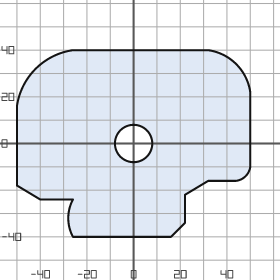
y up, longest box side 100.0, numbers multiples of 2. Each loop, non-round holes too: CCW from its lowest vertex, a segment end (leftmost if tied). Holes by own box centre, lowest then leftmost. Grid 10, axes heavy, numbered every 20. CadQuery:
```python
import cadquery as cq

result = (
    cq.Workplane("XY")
    .moveTo(-26.0, -40.0)
    .lineTo(16.0, -40.0)
    .lineTo(22.0, -34.0)
    .lineTo(22.0, -22.0)
    .lineTo(32.0, -16.0)
    .lineTo(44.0, -16.0)
    .threePointArc((48.0, -14.0), (50.0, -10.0))
    .lineTo(50.0, 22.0)
    .threePointArc((44.0, 34.0), (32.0, 40.0))
    .lineTo(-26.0, 40.0)
    .threePointArc((-42.0, 32.0), (-50.0, 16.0))
    .lineTo(-50.0, -18.0)
    .lineTo(-40.0, -24.0)
    .lineTo(-26.0, -24.0)
    .threePointArc((-28.0, -32.0), (-26.0, -40.0))
    .close()
    .moveTo(0.0, 0.0)
    .circle(8.0)
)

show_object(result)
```